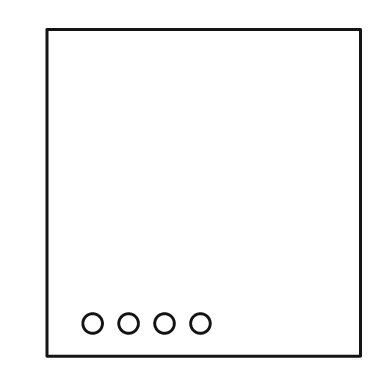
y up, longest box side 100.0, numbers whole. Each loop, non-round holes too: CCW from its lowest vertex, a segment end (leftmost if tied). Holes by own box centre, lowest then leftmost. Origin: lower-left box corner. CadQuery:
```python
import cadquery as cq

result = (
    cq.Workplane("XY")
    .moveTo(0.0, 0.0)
    .lineTo(96.0, 0.0)
    .lineTo(96.0, 100.0)
    .lineTo(0.0, 100.0)
    .close()
    .moveTo(14.0, 10.0)
    .circle(3.0)
    .moveTo(25.0, 10.0)
    .circle(3.0)
    .moveTo(36.0, 10.0)
    .circle(3.0)
    .moveTo(47.0, 10.0)
    .circle(3.0)
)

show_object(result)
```